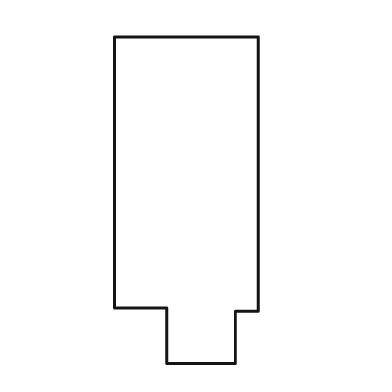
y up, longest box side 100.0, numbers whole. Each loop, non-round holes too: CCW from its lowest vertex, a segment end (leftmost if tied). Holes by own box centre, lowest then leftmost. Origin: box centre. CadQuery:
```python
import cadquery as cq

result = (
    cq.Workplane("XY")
    .moveTo(-6.0, -50.0)
    .lineTo(15.0, -50.0)
    .lineTo(15.0, -34.0)
    .lineTo(22.0, -34.0)
    .lineTo(22.0, 50.0)
    .lineTo(-22.0, 50.0)
    .lineTo(-22.0, -33.0)
    .lineTo(-6.0, -33.0)
    .close()
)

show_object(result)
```